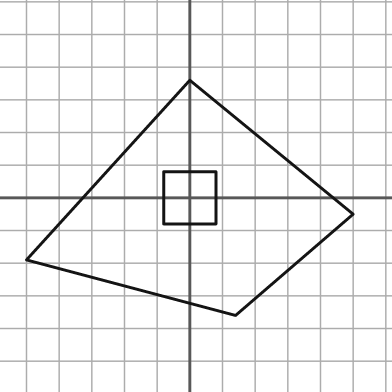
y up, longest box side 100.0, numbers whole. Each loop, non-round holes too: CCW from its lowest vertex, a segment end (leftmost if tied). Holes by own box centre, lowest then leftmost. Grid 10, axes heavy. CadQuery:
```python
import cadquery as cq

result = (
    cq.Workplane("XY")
    .moveTo(14.0, -36.0)
    .lineTo(50.0, -5.0)
    .lineTo(0.0, 36.0)
    .lineTo(-50.0, -19.0)
    .close()
    .moveTo(-8.0, -8.0)
    .lineTo(8.0, -8.0)
    .lineTo(8.0, 8.0)
    .lineTo(-8.0, 8.0)
    .close()
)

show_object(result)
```